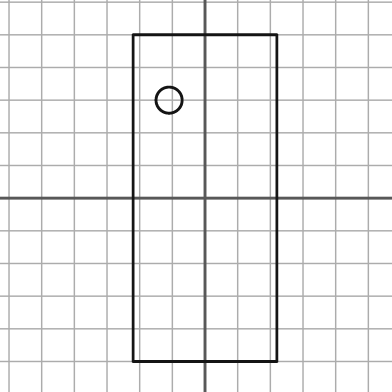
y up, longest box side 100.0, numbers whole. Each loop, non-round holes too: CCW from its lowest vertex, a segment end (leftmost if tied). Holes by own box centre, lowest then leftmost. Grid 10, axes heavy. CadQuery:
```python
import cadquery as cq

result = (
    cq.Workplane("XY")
    .moveTo(-22.0, -50.0)
    .lineTo(22.0, -50.0)
    .lineTo(22.0, 50.0)
    .lineTo(-22.0, 50.0)
    .close()
    .moveTo(-11.0, 30.0)
    .circle(4.0)
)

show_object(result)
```